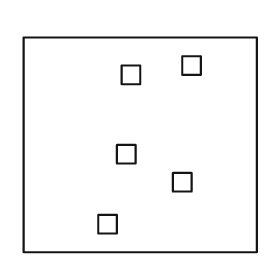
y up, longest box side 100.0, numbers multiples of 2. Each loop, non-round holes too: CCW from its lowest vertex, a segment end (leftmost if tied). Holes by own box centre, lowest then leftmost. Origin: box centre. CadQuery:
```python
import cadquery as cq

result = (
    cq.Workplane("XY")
    .moveTo(-50.0, -46.0)
    .lineTo(50.0, -46.0)
    .lineTo(50.0, 46.0)
    .lineTo(-50.0, 46.0)
    .close()
    .moveTo(-18.0, -38.0)
    .lineTo(-10.0, -38.0)
    .lineTo(-10.0, -30.0)
    .lineTo(-18.0, -30.0)
    .close()
    .moveTo(14.0, -20.0)
    .lineTo(22.0, -20.0)
    .lineTo(22.0, -12.0)
    .lineTo(14.0, -12.0)
    .close()
    .moveTo(-10.0, -8.0)
    .lineTo(-2.0, -8.0)
    .lineTo(-2.0, 0.0)
    .lineTo(-10.0, 0.0)
    .close()
    .moveTo(-8.0, 26.0)
    .lineTo(0.0, 26.0)
    .lineTo(0.0, 34.0)
    .lineTo(-8.0, 34.0)
    .close()
    .moveTo(18.0, 30.0)
    .lineTo(26.0, 30.0)
    .lineTo(26.0, 38.0)
    .lineTo(18.0, 38.0)
    .close()
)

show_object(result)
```